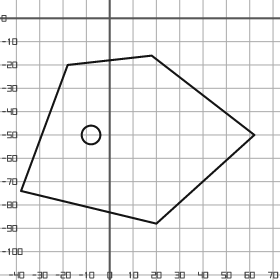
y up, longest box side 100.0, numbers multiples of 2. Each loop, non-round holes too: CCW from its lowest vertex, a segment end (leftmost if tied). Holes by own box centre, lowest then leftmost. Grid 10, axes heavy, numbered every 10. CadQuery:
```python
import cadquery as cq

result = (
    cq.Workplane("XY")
    .moveTo(20.0, -88.0)
    .lineTo(62.0, -50.0)
    .lineTo(18.0, -16.0)
    .lineTo(-18.0, -20.0)
    .lineTo(-38.0, -74.0)
    .close()
    .moveTo(-8.0, -50.0)
    .circle(4.0)
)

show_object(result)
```